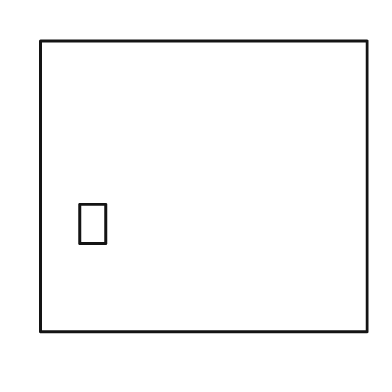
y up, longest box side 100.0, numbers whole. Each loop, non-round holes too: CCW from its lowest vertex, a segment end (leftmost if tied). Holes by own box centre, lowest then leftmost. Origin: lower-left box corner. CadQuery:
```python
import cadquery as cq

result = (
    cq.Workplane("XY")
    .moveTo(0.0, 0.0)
    .lineTo(100.0, 0.0)
    .lineTo(100.0, 89.0)
    .lineTo(0.0, 89.0)
    .close()
    .moveTo(12.0, 27.0)
    .lineTo(20.0, 27.0)
    .lineTo(20.0, 39.0)
    .lineTo(12.0, 39.0)
    .close()
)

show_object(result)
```